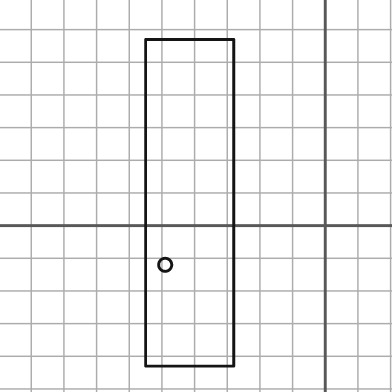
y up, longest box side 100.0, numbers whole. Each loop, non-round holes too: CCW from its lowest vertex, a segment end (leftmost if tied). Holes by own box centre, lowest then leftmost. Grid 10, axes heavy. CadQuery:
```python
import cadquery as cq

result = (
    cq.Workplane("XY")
    .moveTo(-55.0, -43.0)
    .lineTo(-28.0, -43.0)
    .lineTo(-28.0, 57.0)
    .lineTo(-55.0, 57.0)
    .close()
    .moveTo(-49.0, -12.0)
    .circle(2.0)
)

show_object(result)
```